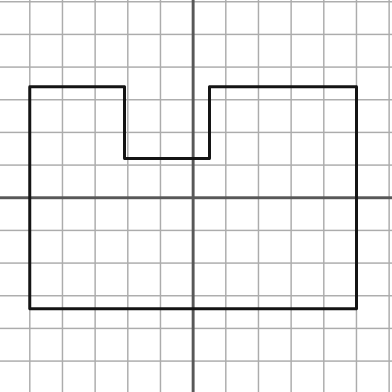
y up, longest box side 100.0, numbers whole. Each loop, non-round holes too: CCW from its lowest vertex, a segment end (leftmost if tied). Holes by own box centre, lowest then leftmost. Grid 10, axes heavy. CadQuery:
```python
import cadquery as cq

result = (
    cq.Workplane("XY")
    .moveTo(-50.0, -34.0)
    .lineTo(50.0, -34.0)
    .lineTo(50.0, 34.0)
    .lineTo(5.0, 34.0)
    .lineTo(5.0, 12.0)
    .lineTo(-21.0, 12.0)
    .lineTo(-21.0, 34.0)
    .lineTo(-50.0, 34.0)
    .close()
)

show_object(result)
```